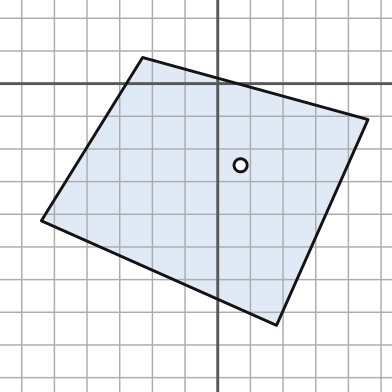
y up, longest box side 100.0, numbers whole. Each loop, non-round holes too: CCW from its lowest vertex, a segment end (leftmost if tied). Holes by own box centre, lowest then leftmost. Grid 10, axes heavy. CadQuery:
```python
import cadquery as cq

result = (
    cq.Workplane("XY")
    .moveTo(18.0, -74.0)
    .lineTo(46.0, -11.0)
    .lineTo(-23.0, 8.0)
    .lineTo(-54.0, -42.0)
    .close()
    .moveTo(7.0, -25.0)
    .circle(2.0)
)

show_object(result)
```